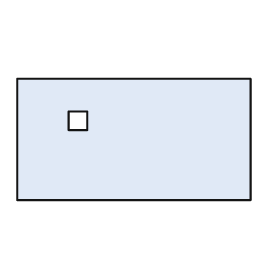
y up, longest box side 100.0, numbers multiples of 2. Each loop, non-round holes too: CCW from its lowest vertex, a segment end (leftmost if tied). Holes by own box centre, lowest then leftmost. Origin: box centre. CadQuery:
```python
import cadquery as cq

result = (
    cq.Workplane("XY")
    .moveTo(-50.0, -26.0)
    .lineTo(50.0, -26.0)
    .lineTo(50.0, 26.0)
    .lineTo(-50.0, 26.0)
    .close()
    .moveTo(-28.0, 4.0)
    .lineTo(-20.0, 4.0)
    .lineTo(-20.0, 12.0)
    .lineTo(-28.0, 12.0)
    .close()
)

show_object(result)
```